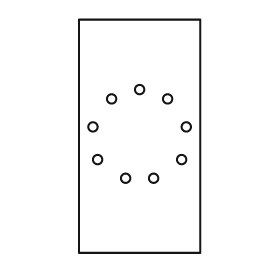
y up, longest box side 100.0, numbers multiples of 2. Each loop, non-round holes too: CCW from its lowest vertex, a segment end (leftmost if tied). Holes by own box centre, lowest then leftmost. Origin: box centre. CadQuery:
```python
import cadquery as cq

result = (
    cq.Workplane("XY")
    .moveTo(-26.0, -50.0)
    .lineTo(26.0, -50.0)
    .lineTo(26.0, 50.0)
    .lineTo(-26.0, 50.0)
    .close()
    .moveTo(-6.0, -18.0)
    .circle(2.0)
    .moveTo(6.0, -18.0)
    .circle(2.0)
    .moveTo(-18.0, -10.0)
    .circle(2.0)
    .moveTo(18.0, -10.0)
    .circle(2.0)
    .moveTo(-20.0, 4.0)
    .circle(2.0)
    .moveTo(20.0, 4.0)
    .circle(2.0)
    .moveTo(-12.0, 16.0)
    .circle(2.0)
    .moveTo(12.0, 16.0)
    .circle(2.0)
    .moveTo(0.0, 20.0)
    .circle(2.0)
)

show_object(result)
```